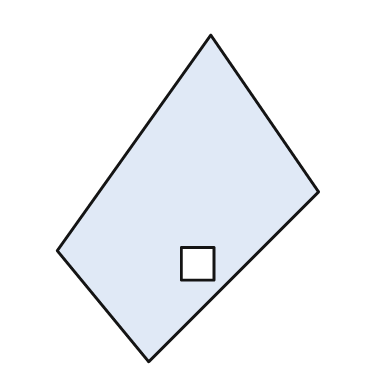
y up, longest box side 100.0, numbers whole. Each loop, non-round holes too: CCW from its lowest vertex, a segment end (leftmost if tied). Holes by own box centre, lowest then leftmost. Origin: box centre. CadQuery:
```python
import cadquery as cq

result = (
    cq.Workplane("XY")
    .moveTo(-12.0, -50.0)
    .lineTo(40.0, 2.0)
    .lineTo(7.0, 50.0)
    .lineTo(-40.0, -16.0)
    .close()
    .moveTo(-2.0, -25.0)
    .lineTo(8.0, -25.0)
    .lineTo(8.0, -15.0)
    .lineTo(-2.0, -15.0)
    .close()
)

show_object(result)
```